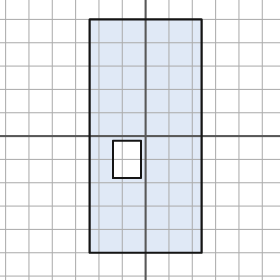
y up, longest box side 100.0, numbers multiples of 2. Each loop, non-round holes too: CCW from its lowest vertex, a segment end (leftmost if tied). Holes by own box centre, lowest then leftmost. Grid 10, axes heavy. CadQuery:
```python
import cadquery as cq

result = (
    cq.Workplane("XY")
    .moveTo(-24.0, -50.0)
    .lineTo(24.0, -50.0)
    .lineTo(24.0, 50.0)
    .lineTo(-24.0, 50.0)
    .close()
    .moveTo(-14.0, -18.0)
    .lineTo(-2.0, -18.0)
    .lineTo(-2.0, -2.0)
    .lineTo(-14.0, -2.0)
    .close()
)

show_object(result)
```